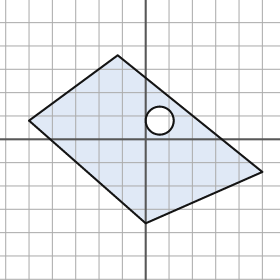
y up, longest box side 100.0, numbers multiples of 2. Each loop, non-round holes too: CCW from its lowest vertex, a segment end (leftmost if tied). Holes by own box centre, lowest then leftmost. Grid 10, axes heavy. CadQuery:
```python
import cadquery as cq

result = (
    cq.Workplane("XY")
    .moveTo(0.0, -36.0)
    .lineTo(50.0, -14.0)
    .lineTo(-12.0, 36.0)
    .lineTo(-50.0, 8.0)
    .close()
    .moveTo(6.0, 8.0)
    .circle(6.0)
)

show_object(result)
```